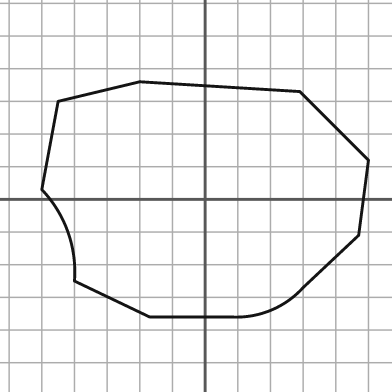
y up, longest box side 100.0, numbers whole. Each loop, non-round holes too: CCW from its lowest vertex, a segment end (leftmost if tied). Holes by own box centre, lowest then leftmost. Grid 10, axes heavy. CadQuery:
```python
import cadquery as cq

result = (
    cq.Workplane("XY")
    .moveTo(-17.0, -36.0)
    .lineTo(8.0, -36.0)
    .threePointArc((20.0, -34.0), (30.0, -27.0))
    .lineTo(47.0, -11.0)
    .lineTo(50.0, 12.0)
    .lineTo(29.0, 33.0)
    .lineTo(-20.0, 36.0)
    .lineTo(-45.0, 30.0)
    .lineTo(-50.0, 3.0)
    .threePointArc((-42.0, -10.0), (-40.0, -25.0))
    .close()
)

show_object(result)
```